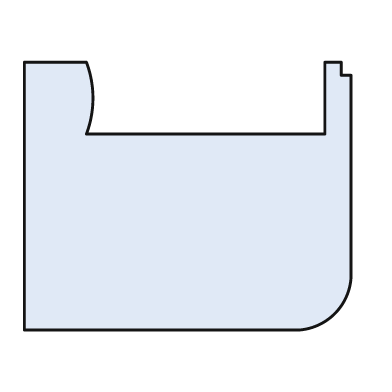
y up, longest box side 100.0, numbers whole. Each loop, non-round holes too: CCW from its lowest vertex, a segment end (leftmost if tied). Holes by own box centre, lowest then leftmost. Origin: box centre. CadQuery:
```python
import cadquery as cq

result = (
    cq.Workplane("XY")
    .moveTo(-50.0, -41.0)
    .lineTo(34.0, -41.0)
    .threePointArc((45.0, -36.0), (50.0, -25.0))
    .lineTo(50.0, 37.0)
    .lineTo(47.0, 37.0)
    .lineTo(47.0, 41.0)
    .lineTo(42.0, 41.0)
    .lineTo(42.0, 19.0)
    .lineTo(-31.0, 19.0)
    .threePointArc((-29.0, 30.0), (-31.0, 41.0))
    .lineTo(-50.0, 41.0)
    .close()
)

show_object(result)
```